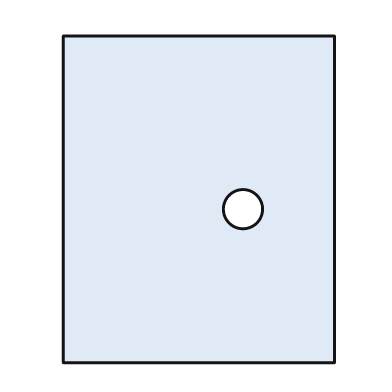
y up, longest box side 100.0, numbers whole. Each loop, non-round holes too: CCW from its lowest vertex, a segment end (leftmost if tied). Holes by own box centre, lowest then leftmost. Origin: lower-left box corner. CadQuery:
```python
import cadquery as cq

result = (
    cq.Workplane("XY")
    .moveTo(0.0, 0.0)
    .lineTo(83.0, 0.0)
    .lineTo(83.0, 100.0)
    .lineTo(0.0, 100.0)
    .close()
    .moveTo(55.0, 47.0)
    .circle(6.0)
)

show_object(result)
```